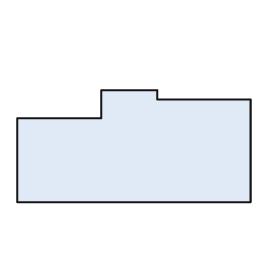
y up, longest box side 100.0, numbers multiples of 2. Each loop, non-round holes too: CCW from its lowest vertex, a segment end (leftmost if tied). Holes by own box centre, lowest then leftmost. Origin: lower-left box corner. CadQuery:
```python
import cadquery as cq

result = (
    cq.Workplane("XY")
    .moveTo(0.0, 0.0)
    .lineTo(100.0, 0.0)
    .lineTo(100.0, 44.0)
    .lineTo(60.0, 44.0)
    .lineTo(60.0, 48.0)
    .lineTo(36.0, 48.0)
    .lineTo(36.0, 36.0)
    .lineTo(0.0, 36.0)
    .close()
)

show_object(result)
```